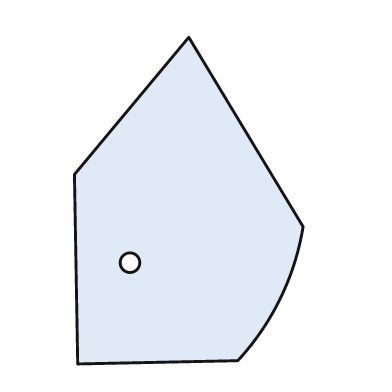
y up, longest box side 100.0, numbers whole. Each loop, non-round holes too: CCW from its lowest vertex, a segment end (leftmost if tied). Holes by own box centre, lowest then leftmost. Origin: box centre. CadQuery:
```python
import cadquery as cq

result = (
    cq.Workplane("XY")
    .moveTo(-34.0, -50.0)
    .lineTo(15.0, -49.0)
    .threePointArc((28.0, -30.0), (35.0, -8.0))
    .lineTo(0.0, 50.0)
    .lineTo(-35.0, 8.0)
    .close()
    .moveTo(-18.0, -19.0)
    .circle(3.0)
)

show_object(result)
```